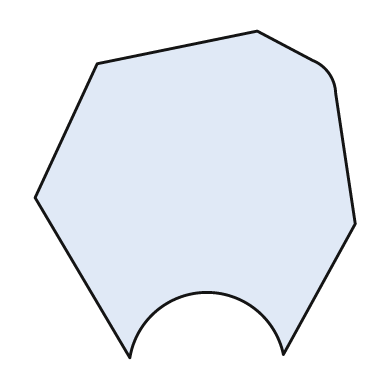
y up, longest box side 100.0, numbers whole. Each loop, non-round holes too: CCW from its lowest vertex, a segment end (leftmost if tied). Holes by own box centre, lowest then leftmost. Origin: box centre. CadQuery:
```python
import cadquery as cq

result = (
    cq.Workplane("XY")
    .moveTo(-20.0, -50.0)
    .threePointArc((3.0, -30.0), (27.0, -49.0))
    .lineTo(49.0, -9.0)
    .lineTo(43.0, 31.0)
    .threePointArc((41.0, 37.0), (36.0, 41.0))
    .lineTo(19.0, 50.0)
    .lineTo(-30.0, 40.0)
    .lineTo(-49.0, -1.0)
    .close()
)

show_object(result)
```